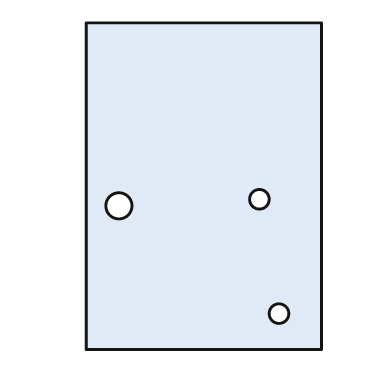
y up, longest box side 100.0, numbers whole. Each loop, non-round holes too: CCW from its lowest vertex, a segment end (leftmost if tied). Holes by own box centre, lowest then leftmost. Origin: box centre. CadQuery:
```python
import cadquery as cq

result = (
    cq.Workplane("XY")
    .moveTo(-36.0, -50.0)
    .lineTo(36.0, -50.0)
    .lineTo(36.0, 50.0)
    .lineTo(-36.0, 50.0)
    .close()
    .moveTo(23.0, -39.0)
    .circle(3.0)
    .moveTo(-26.0, -6.0)
    .circle(4.0)
    .moveTo(17.0, -4.0)
    .circle(3.0)
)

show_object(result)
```